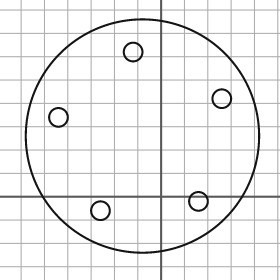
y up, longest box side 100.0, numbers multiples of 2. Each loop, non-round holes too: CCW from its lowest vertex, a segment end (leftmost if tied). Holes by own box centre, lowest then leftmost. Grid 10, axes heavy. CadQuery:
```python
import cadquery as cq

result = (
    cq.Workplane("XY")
    .moveTo(-8.0, 26.0)
    .circle(50.0)
    .moveTo(-26.0, -6.0)
    .circle(4.0)
    .moveTo(16.0, -2.0)
    .circle(4.0)
    .moveTo(-44.0, 34.0)
    .circle(4.0)
    .moveTo(26.0, 42.0)
    .circle(4.0)
    .moveTo(-12.0, 62.0)
    .circle(4.0)
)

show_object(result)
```